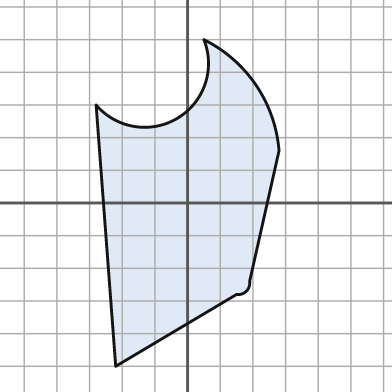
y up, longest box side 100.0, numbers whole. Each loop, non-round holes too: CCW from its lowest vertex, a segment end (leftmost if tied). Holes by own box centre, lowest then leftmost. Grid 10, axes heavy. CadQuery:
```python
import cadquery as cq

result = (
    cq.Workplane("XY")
    .moveTo(-22.0, -50.0)
    .lineTo(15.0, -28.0)
    .threePointArc((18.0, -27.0), (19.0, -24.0))
    .lineTo(28.0, 16.0)
    .threePointArc((21.0, 36.0), (5.0, 50.0))
    .threePointArc((-3.0, 26.0), (-28.0, 30.0))
    .close()
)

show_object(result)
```